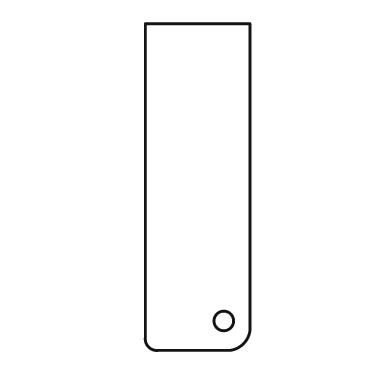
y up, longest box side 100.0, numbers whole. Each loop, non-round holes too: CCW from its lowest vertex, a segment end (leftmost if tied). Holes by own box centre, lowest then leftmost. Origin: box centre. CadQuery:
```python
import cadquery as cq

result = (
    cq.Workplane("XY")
    .moveTo(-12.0, -50.0)
    .lineTo(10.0, -50.0)
    .threePointArc((14.0, -48.0), (16.0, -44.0))
    .lineTo(16.0, 50.0)
    .lineTo(-16.0, 50.0)
    .lineTo(-16.0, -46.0)
    .threePointArc((-15.0, -49.0), (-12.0, -50.0))
    .close()
    .moveTo(8.0, -41.0)
    .circle(3.0)
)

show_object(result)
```